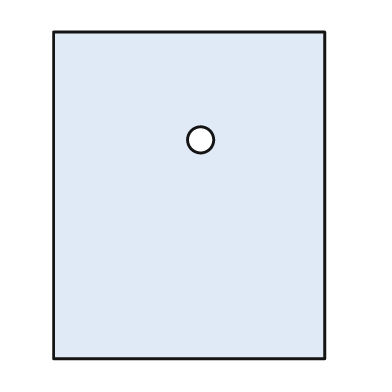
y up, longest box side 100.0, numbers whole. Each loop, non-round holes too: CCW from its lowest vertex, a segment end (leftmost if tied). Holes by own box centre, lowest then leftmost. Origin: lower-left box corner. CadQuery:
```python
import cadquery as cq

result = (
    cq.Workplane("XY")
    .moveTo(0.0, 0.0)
    .lineTo(83.0, 0.0)
    .lineTo(83.0, 100.0)
    .lineTo(0.0, 100.0)
    .close()
    .moveTo(45.0, 67.0)
    .circle(4.0)
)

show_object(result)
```